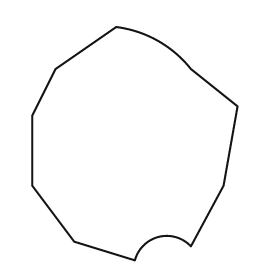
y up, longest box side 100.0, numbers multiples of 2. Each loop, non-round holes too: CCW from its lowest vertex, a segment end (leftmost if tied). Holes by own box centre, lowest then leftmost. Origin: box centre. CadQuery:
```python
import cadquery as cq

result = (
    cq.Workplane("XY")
    .moveTo(0.0, -50.0)
    .threePointArc((10.0, -40.0), (24.0, -44.0))
    .lineTo(38.0, -18.0)
    .lineTo(44.0, 16.0)
    .lineTo(24.0, 32.0)
    .threePointArc((10.0, 44.0), (-8.0, 50.0))
    .lineTo(-34.0, 32.0)
    .lineTo(-44.0, 12.0)
    .lineTo(-44.0, -18.0)
    .lineTo(-26.0, -42.0)
    .close()
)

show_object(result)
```